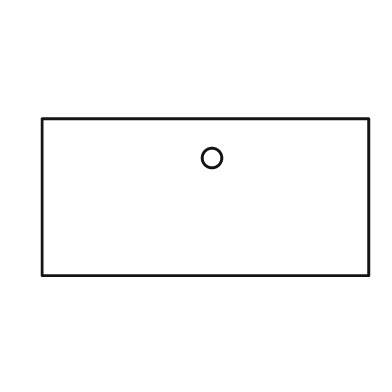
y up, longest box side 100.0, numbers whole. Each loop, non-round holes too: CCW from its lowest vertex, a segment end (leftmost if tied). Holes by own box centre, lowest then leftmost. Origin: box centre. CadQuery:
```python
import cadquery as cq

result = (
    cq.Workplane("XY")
    .moveTo(-50.0, -24.0)
    .lineTo(50.0, -24.0)
    .lineTo(50.0, 24.0)
    .lineTo(-50.0, 24.0)
    .close()
    .moveTo(2.0, 12.0)
    .circle(3.0)
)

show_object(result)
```